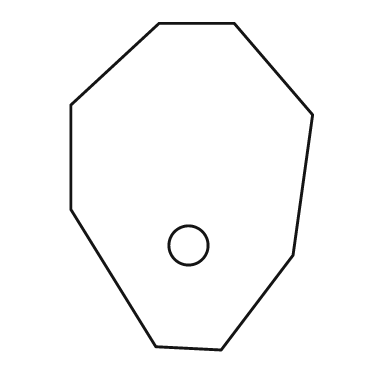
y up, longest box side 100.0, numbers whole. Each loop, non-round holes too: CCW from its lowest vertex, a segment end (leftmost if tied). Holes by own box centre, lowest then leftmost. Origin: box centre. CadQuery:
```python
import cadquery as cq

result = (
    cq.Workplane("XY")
    .moveTo(9.0, -50.0)
    .lineTo(31.0, -21.0)
    .lineTo(37.0, 22.0)
    .lineTo(13.0, 50.0)
    .lineTo(-10.0, 50.0)
    .lineTo(-37.0, 25.0)
    .lineTo(-37.0, -7.0)
    .lineTo(-11.0, -49.0)
    .close()
    .moveTo(-1.0, -18.0)
    .circle(6.0)
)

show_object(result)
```